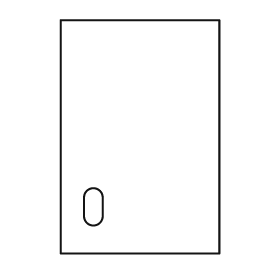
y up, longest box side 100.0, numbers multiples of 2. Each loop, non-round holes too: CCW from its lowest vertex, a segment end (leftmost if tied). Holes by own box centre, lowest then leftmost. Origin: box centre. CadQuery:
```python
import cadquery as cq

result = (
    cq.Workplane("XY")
    .moveTo(-34.0, -50.0)
    .lineTo(34.0, -50.0)
    .lineTo(34.0, 50.0)
    .lineTo(-34.0, 50.0)
    .close()
    .moveTo(-24.0, -34.0)
    .threePointArc((-20.0, -38.0), (-16.0, -34.0))
    .lineTo(-16.0, -26.0)
    .threePointArc((-20.0, -22.0), (-24.0, -26.0))
    .close()
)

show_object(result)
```